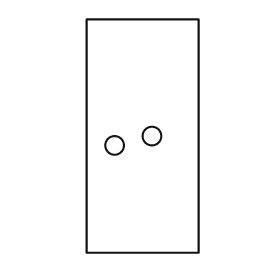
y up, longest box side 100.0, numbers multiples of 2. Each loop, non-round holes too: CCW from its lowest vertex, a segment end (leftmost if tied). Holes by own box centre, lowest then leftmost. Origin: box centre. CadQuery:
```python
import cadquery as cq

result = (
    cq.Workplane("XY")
    .moveTo(-24.0, -50.0)
    .lineTo(24.0, -50.0)
    .lineTo(24.0, 50.0)
    .lineTo(-24.0, 50.0)
    .close()
    .moveTo(-12.0, -4.0)
    .circle(4.0)
    .moveTo(4.0, 0.0)
    .circle(4.0)
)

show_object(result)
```